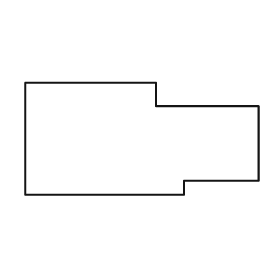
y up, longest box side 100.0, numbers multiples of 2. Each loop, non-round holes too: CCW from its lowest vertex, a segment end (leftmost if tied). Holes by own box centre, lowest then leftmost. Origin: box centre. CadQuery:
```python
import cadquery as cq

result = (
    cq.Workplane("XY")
    .moveTo(-50.0, -24.0)
    .lineTo(18.0, -24.0)
    .lineTo(18.0, -18.0)
    .lineTo(50.0, -18.0)
    .lineTo(50.0, 14.0)
    .lineTo(6.0, 14.0)
    .lineTo(6.0, 24.0)
    .lineTo(-50.0, 24.0)
    .close()
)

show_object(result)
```